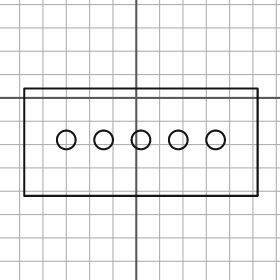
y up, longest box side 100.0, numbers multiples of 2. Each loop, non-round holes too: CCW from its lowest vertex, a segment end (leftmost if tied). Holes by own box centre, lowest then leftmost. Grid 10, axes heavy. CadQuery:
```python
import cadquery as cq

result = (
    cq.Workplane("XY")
    .moveTo(-48.0, -42.0)
    .lineTo(52.0, -42.0)
    .lineTo(52.0, 4.0)
    .lineTo(-48.0, 4.0)
    .close()
    .moveTo(-30.0, -18.0)
    .circle(4.0)
    .moveTo(-14.0, -18.0)
    .circle(4.0)
    .moveTo(2.0, -18.0)
    .circle(4.0)
    .moveTo(18.0, -18.0)
    .circle(4.0)
    .moveTo(34.0, -18.0)
    .circle(4.0)
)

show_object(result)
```